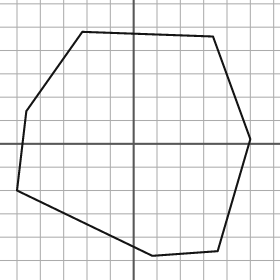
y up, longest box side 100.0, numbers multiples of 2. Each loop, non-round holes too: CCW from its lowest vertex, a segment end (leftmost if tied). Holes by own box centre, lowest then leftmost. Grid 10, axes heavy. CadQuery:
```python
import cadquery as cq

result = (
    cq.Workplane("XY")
    .moveTo(8.0, -48.0)
    .lineTo(36.0, -46.0)
    .lineTo(50.0, 2.0)
    .lineTo(34.0, 46.0)
    .lineTo(-22.0, 48.0)
    .lineTo(-46.0, 14.0)
    .lineTo(-50.0, -20.0)
    .close()
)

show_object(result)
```